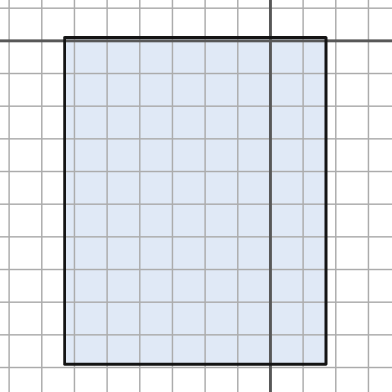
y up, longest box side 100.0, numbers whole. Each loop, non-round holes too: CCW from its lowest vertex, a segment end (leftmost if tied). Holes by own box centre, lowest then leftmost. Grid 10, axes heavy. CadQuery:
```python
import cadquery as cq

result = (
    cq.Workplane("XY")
    .moveTo(-63.0, -99.0)
    .lineTo(17.0, -99.0)
    .lineTo(17.0, 1.0)
    .lineTo(-63.0, 1.0)
    .close()
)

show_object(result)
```